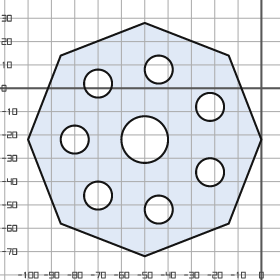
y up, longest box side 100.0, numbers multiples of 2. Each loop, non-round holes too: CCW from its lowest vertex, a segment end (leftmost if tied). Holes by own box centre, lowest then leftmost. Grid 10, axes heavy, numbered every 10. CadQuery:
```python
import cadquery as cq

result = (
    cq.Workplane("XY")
    .moveTo(-50.0, -72.0)
    .lineTo(-14.0, -58.0)
    .lineTo(0.0, -22.0)
    .lineTo(-14.0, 14.0)
    .lineTo(-50.0, 28.0)
    .lineTo(-86.0, 14.0)
    .lineTo(-100.0, -22.0)
    .lineTo(-86.0, -58.0)
    .close()
    .moveTo(-44.0, -52.0)
    .circle(6.0)
    .moveTo(-70.0, -46.0)
    .circle(6.0)
    .moveTo(-22.0, -36.0)
    .circle(6.0)
    .moveTo(-80.0, -22.0)
    .circle(6.0)
    .moveTo(-50.0, -22.0)
    .circle(10.0)
    .moveTo(-22.0, -8.0)
    .circle(6.0)
    .moveTo(-70.0, 2.0)
    .circle(6.0)
    .moveTo(-44.0, 8.0)
    .circle(6.0)
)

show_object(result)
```